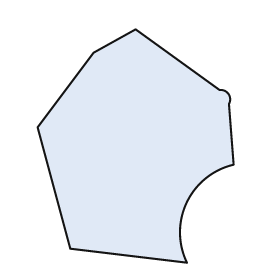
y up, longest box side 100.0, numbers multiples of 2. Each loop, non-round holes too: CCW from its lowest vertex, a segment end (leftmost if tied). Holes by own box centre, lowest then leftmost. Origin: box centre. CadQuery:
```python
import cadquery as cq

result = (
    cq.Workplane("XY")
    .moveTo(22.0, -50.0)
    .threePointArc((22.0, -24.0), (42.0, -8.0))
    .lineTo(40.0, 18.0)
    .threePointArc((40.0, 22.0), (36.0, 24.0))
    .lineTo(0.0, 50.0)
    .lineTo(-18.0, 40.0)
    .lineTo(-42.0, 8.0)
    .lineTo(-28.0, -44.0)
    .close()
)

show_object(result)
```